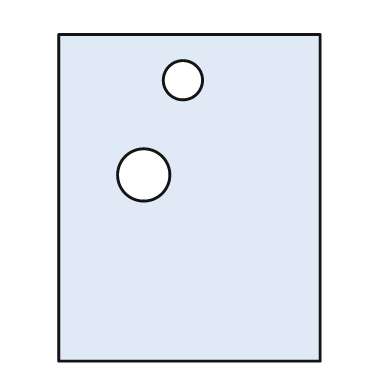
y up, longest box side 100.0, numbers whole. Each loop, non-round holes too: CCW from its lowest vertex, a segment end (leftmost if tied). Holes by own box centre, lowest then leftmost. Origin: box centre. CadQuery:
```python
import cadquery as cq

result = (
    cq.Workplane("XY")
    .moveTo(-40.0, -50.0)
    .lineTo(40.0, -50.0)
    .lineTo(40.0, 50.0)
    .lineTo(-40.0, 50.0)
    .close()
    .moveTo(-14.0, 7.0)
    .circle(8.0)
    .moveTo(-2.0, 36.0)
    .circle(6.0)
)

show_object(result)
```